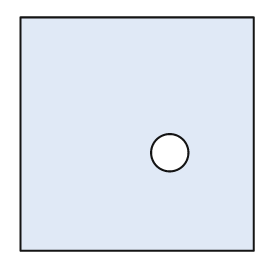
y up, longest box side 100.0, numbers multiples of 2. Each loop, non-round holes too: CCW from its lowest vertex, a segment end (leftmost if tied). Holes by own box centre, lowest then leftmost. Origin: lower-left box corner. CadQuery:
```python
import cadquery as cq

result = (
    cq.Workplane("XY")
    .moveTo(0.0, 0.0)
    .lineTo(100.0, 0.0)
    .lineTo(100.0, 100.0)
    .lineTo(0.0, 100.0)
    .close()
    .moveTo(64.0, 42.0)
    .circle(8.0)
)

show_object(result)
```